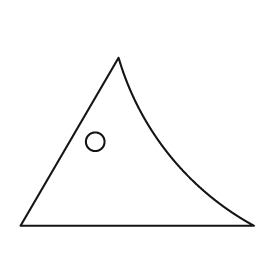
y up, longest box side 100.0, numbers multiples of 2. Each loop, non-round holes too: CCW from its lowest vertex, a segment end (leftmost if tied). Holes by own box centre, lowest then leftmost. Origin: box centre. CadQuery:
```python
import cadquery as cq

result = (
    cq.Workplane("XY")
    .moveTo(-50.0, -36.0)
    .lineTo(50.0, -36.0)
    .threePointArc((14.0, -6.0), (-8.0, 36.0))
    .close()
    .moveTo(-18.0, 0.0)
    .circle(4.0)
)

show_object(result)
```